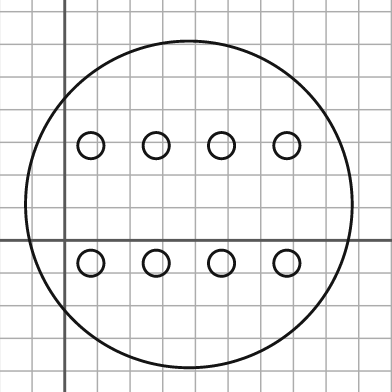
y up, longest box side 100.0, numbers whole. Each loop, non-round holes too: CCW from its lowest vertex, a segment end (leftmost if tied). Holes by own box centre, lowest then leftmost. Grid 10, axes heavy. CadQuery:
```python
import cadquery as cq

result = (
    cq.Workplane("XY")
    .moveTo(38.0, 11.0)
    .circle(50.0)
    .moveTo(8.0, -7.0)
    .circle(4.0)
    .moveTo(28.0, -7.0)
    .circle(4.0)
    .moveTo(48.0, -7.0)
    .circle(4.0)
    .moveTo(68.0, -7.0)
    .circle(4.0)
    .moveTo(8.0, 29.0)
    .circle(4.0)
    .moveTo(28.0, 29.0)
    .circle(4.0)
    .moveTo(48.0, 29.0)
    .circle(4.0)
    .moveTo(68.0, 29.0)
    .circle(4.0)
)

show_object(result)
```